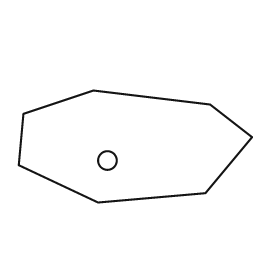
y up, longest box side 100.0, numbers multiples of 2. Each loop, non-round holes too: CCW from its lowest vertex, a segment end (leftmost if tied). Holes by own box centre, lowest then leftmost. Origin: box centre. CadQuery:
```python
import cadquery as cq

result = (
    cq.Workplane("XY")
    .moveTo(-16.0, -24.0)
    .lineTo(30.0, -20.0)
    .lineTo(50.0, 4.0)
    .lineTo(32.0, 18.0)
    .lineTo(-18.0, 24.0)
    .lineTo(-48.0, 14.0)
    .lineTo(-50.0, -8.0)
    .close()
    .moveTo(-12.0, -6.0)
    .circle(4.0)
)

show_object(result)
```